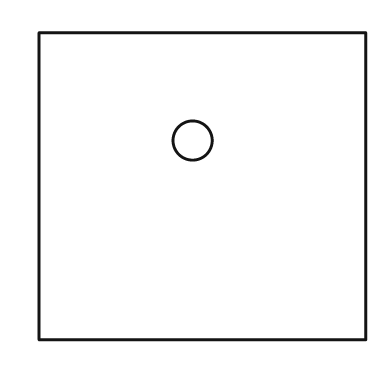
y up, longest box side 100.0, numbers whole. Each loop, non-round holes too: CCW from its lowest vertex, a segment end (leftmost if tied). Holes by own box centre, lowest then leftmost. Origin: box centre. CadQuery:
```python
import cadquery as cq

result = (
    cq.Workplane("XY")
    .moveTo(-50.0, -47.0)
    .lineTo(50.0, -47.0)
    .lineTo(50.0, 47.0)
    .lineTo(-50.0, 47.0)
    .close()
    .moveTo(-3.0, 14.0)
    .circle(6.0)
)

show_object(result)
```